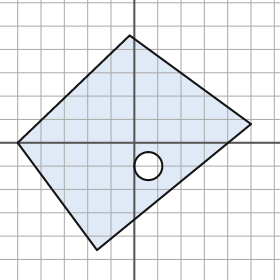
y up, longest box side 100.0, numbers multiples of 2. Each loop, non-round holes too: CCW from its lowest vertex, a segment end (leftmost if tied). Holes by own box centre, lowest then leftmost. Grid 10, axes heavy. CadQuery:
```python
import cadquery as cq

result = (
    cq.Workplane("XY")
    .moveTo(-16.0, -46.0)
    .lineTo(50.0, 8.0)
    .lineTo(-2.0, 46.0)
    .lineTo(-50.0, 0.0)
    .close()
    .moveTo(6.0, -10.0)
    .circle(6.0)
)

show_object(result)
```